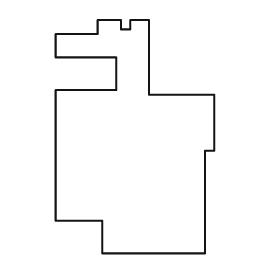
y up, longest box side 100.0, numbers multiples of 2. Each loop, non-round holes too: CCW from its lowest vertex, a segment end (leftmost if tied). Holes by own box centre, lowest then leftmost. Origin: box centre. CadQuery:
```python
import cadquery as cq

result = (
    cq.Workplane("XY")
    .moveTo(-14.0, -50.0)
    .lineTo(30.0, -50.0)
    .lineTo(30.0, -6.0)
    .lineTo(34.0, -6.0)
    .lineTo(34.0, 18.0)
    .lineTo(6.0, 18.0)
    .lineTo(6.0, 50.0)
    .lineTo(-2.0, 50.0)
    .lineTo(-2.0, 46.0)
    .lineTo(-6.0, 46.0)
    .lineTo(-6.0, 50.0)
    .lineTo(-16.0, 50.0)
    .lineTo(-16.0, 44.0)
    .lineTo(-34.0, 44.0)
    .lineTo(-34.0, 34.0)
    .lineTo(-8.0, 34.0)
    .lineTo(-8.0, 20.0)
    .lineTo(-34.0, 20.0)
    .lineTo(-34.0, -36.0)
    .lineTo(-14.0, -36.0)
    .close()
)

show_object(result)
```